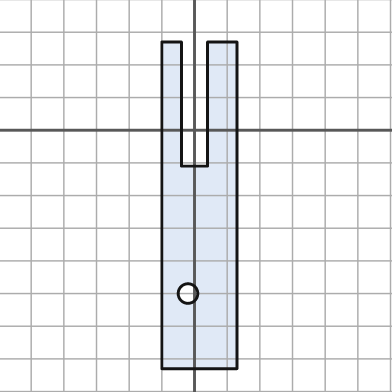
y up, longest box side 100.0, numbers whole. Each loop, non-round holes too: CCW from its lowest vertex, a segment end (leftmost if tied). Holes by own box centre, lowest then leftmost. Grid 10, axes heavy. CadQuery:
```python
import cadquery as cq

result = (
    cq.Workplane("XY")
    .moveTo(-10.0, -73.0)
    .lineTo(13.0, -73.0)
    .lineTo(13.0, 27.0)
    .lineTo(4.0, 27.0)
    .lineTo(4.0, -11.0)
    .lineTo(-4.0, -11.0)
    .lineTo(-4.0, 27.0)
    .lineTo(-10.0, 27.0)
    .close()
    .moveTo(-2.0, -50.0)
    .circle(3.0)
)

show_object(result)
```